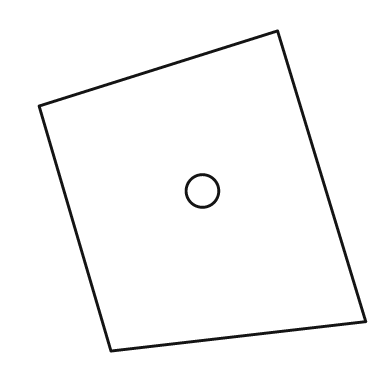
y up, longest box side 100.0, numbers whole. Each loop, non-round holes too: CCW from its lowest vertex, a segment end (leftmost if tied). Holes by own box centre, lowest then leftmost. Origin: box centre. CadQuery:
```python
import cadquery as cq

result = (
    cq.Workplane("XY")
    .moveTo(-28.0, -49.0)
    .lineTo(50.0, -40.0)
    .lineTo(23.0, 49.0)
    .lineTo(-50.0, 26.0)
    .close()
    .moveTo(0.0, 0.0)
    .circle(5.0)
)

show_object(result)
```